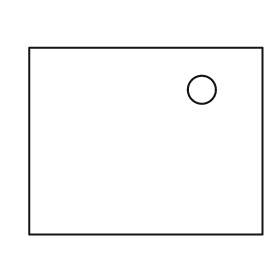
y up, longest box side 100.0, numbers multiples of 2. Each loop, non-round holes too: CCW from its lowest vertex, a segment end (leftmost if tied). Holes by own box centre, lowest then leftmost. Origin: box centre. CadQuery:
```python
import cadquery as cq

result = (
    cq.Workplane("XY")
    .moveTo(-50.0, -40.0)
    .lineTo(50.0, -40.0)
    .lineTo(50.0, 40.0)
    .lineTo(-50.0, 40.0)
    .close()
    .moveTo(24.0, 22.0)
    .circle(6.0)
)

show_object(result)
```